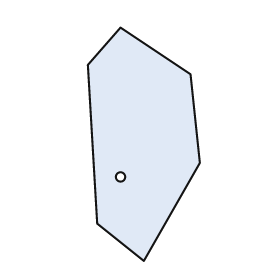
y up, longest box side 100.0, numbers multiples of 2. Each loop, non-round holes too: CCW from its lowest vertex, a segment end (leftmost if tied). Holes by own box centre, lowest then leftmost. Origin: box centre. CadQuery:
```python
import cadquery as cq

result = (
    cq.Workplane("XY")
    .moveTo(0.0, -50.0)
    .lineTo(24.0, -8.0)
    .lineTo(20.0, 30.0)
    .lineTo(-10.0, 50.0)
    .lineTo(-24.0, 34.0)
    .lineTo(-20.0, -34.0)
    .close()
    .moveTo(-10.0, -14.0)
    .circle(2.0)
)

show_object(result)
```